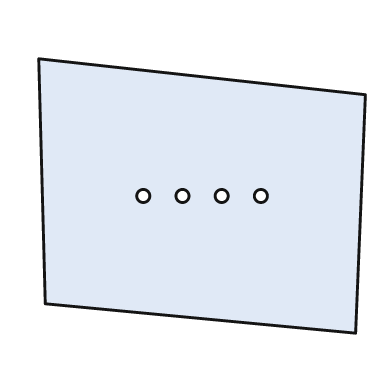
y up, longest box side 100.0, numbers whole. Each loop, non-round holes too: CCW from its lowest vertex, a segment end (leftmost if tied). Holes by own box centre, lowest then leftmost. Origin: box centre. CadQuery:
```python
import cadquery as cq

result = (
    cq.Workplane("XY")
    .moveTo(47.0, -42.0)
    .lineTo(50.0, 31.0)
    .lineTo(-50.0, 42.0)
    .lineTo(-48.0, -33.0)
    .close()
    .moveTo(-18.0, 0.0)
    .circle(2.0)
    .moveTo(-6.0, 0.0)
    .circle(2.0)
    .moveTo(6.0, 0.0)
    .circle(2.0)
    .moveTo(18.0, 0.0)
    .circle(2.0)
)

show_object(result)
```